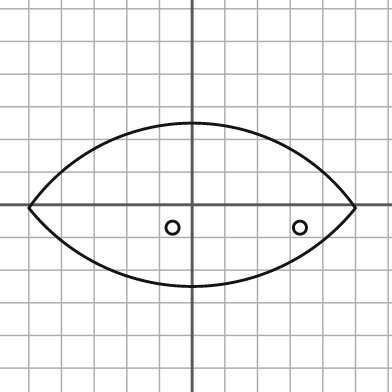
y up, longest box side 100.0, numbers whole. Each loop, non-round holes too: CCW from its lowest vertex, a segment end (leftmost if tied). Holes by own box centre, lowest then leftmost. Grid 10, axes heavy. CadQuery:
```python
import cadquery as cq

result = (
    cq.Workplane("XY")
    .moveTo(-50.0, -1.0)
    .threePointArc((0.0, -25.0), (50.0, -1.0))
    .threePointArc((0.0, 25.0), (-50.0, -1.0))
    .close()
    .moveTo(-6.0, -7.0)
    .circle(2.0)
    .moveTo(33.0, -7.0)
    .circle(2.0)
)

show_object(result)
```